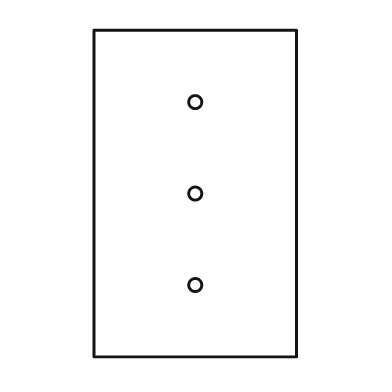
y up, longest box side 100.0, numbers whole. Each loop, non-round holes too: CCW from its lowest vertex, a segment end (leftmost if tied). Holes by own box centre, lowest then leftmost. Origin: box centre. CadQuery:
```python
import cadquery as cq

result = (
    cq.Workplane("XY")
    .moveTo(-31.0, -50.0)
    .lineTo(31.0, -50.0)
    .lineTo(31.0, 50.0)
    .lineTo(-31.0, 50.0)
    .close()
    .moveTo(0.0, -28.0)
    .circle(2.0)
    .moveTo(0.0, 0.0)
    .circle(2.0)
    .moveTo(0.0, 28.0)
    .circle(2.0)
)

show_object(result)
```